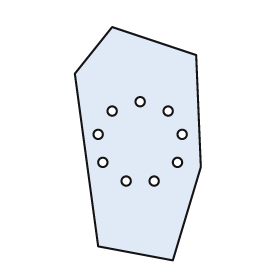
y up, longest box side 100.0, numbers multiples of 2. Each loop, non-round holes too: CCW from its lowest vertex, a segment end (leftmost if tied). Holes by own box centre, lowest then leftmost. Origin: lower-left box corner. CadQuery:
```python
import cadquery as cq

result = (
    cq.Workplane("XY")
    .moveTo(42.0, 0.0)
    .lineTo(54.0, 40.0)
    .lineTo(52.0, 88.0)
    .lineTo(16.0, 100.0)
    .lineTo(0.0, 80.0)
    .lineTo(10.0, 6.0)
    .close()
    .moveTo(22.0, 34.0)
    .circle(2.0)
    .moveTo(34.0, 34.0)
    .circle(2.0)
    .moveTo(12.0, 42.0)
    .circle(2.0)
    .moveTo(44.0, 42.0)
    .circle(2.0)
    .moveTo(10.0, 54.0)
    .circle(2.0)
    .moveTo(46.0, 54.0)
    .circle(2.0)
    .moveTo(16.0, 64.0)
    .circle(2.0)
    .moveTo(40.0, 64.0)
    .circle(2.0)
    .moveTo(28.0, 68.0)
    .circle(2.0)
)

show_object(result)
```